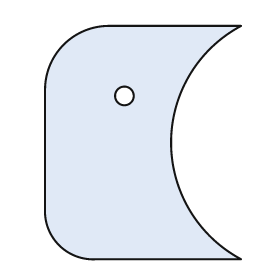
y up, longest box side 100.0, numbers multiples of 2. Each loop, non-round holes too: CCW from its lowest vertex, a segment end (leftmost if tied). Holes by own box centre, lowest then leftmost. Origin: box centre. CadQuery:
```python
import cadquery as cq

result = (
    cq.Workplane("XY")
    .moveTo(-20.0, -50.0)
    .lineTo(42.0, -50.0)
    .threePointArc((12.0, 0.0), (42.0, 50.0))
    .lineTo(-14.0, 50.0)
    .threePointArc((-34.0, 42.0), (-42.0, 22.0))
    .lineTo(-42.0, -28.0)
    .threePointArc((-36.0, -44.0), (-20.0, -50.0))
    .close()
    .moveTo(-8.0, 20.0)
    .circle(4.0)
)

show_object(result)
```